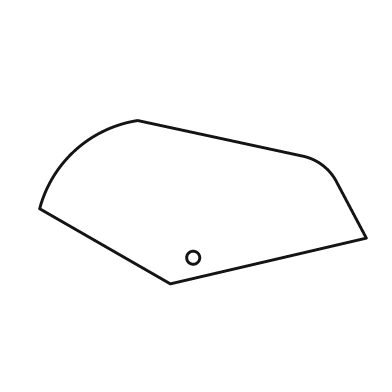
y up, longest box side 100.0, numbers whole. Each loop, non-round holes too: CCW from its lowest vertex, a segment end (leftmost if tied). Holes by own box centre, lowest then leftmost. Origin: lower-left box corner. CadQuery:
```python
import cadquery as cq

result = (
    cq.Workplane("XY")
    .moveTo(40.0, 0.0)
    .lineTo(100.0, 14.0)
    .lineTo(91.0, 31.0)
    .threePointArc((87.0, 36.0), (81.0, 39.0))
    .lineTo(30.0, 50.0)
    .threePointArc((11.0, 41.0), (0.0, 23.0))
    .close()
    .moveTo(47.0, 8.0)
    .circle(2.0)
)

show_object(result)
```